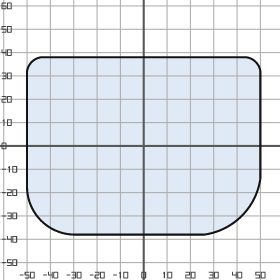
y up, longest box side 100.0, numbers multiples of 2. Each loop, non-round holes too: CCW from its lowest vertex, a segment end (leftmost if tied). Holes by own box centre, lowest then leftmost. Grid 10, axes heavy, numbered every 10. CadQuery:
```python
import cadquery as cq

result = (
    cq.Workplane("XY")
    .moveTo(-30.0, -38.0)
    .lineTo(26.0, -38.0)
    .threePointArc((42.0, -30.0), (50.0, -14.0))
    .lineTo(50.0, 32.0)
    .threePointArc((48.0, 36.0), (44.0, 38.0))
    .lineTo(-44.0, 38.0)
    .threePointArc((-48.0, 36.0), (-50.0, 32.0))
    .lineTo(-50.0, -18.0)
    .threePointArc((-44.0, -32.0), (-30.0, -38.0))
    .close()
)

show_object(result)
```